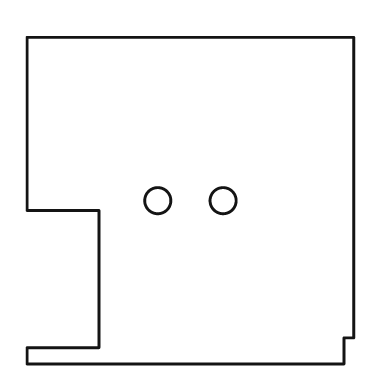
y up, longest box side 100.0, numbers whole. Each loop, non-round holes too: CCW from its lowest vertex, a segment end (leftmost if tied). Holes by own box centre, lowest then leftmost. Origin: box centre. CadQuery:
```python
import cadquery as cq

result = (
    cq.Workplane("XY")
    .moveTo(-50.0, -50.0)
    .lineTo(47.0, -50.0)
    .lineTo(47.0, -42.0)
    .lineTo(50.0, -42.0)
    .lineTo(50.0, 50.0)
    .lineTo(-50.0, 50.0)
    .lineTo(-50.0, -3.0)
    .lineTo(-28.0, -3.0)
    .lineTo(-28.0, -45.0)
    .lineTo(-50.0, -45.0)
    .close()
    .moveTo(-10.0, 0.0)
    .circle(4.0)
    .moveTo(10.0, 0.0)
    .circle(4.0)
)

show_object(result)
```